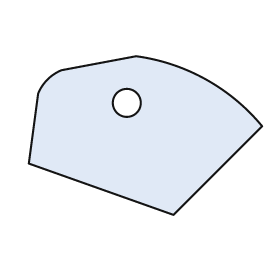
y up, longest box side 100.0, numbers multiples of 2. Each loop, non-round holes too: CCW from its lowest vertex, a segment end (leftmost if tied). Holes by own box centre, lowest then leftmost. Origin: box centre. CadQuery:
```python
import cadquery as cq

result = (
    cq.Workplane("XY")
    .moveTo(12.0, -34.0)
    .lineTo(50.0, 4.0)
    .threePointArc((26.0, 24.0), (-4.0, 34.0))
    .lineTo(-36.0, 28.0)
    .threePointArc((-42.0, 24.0), (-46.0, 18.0))
    .lineTo(-50.0, -12.0)
    .close()
    .moveTo(-8.0, 14.0)
    .circle(6.0)
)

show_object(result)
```